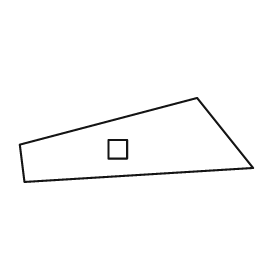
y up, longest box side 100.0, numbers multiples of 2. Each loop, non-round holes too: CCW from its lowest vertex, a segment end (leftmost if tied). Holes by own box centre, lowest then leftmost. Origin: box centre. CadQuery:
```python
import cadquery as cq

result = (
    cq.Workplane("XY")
    .moveTo(-48.0, -18.0)
    .lineTo(50.0, -12.0)
    .lineTo(26.0, 18.0)
    .lineTo(-50.0, -2.0)
    .close()
    .moveTo(-12.0, -8.0)
    .lineTo(-4.0, -8.0)
    .lineTo(-4.0, 0.0)
    .lineTo(-12.0, 0.0)
    .close()
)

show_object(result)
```